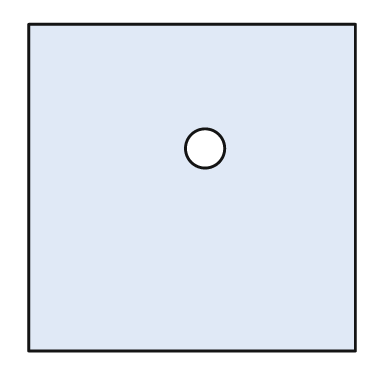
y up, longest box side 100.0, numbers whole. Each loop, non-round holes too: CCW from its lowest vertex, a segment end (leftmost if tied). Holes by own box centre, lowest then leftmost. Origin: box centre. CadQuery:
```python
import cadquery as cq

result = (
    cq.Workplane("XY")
    .moveTo(-50.0, -50.0)
    .lineTo(50.0, -50.0)
    .lineTo(50.0, 50.0)
    .lineTo(-50.0, 50.0)
    .close()
    .moveTo(4.0, 12.0)
    .circle(6.0)
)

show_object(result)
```